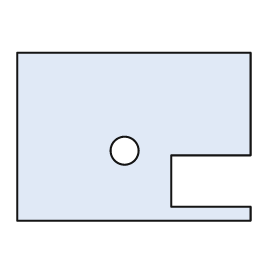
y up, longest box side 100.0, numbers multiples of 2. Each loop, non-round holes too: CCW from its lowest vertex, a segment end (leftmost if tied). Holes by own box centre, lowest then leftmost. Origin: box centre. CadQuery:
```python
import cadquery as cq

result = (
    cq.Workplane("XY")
    .moveTo(-50.0, -36.0)
    .lineTo(50.0, -36.0)
    .lineTo(50.0, -30.0)
    .lineTo(16.0, -30.0)
    .lineTo(16.0, -8.0)
    .lineTo(50.0, -8.0)
    .lineTo(50.0, 36.0)
    .lineTo(-50.0, 36.0)
    .close()
    .moveTo(-4.0, -6.0)
    .circle(6.0)
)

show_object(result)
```